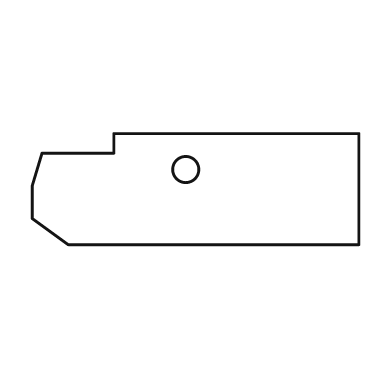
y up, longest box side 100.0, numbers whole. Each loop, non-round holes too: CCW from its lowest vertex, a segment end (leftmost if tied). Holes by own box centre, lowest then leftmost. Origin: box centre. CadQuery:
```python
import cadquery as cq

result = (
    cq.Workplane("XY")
    .moveTo(-39.0, -17.0)
    .lineTo(50.0, -17.0)
    .lineTo(50.0, 17.0)
    .lineTo(-25.0, 17.0)
    .lineTo(-25.0, 11.0)
    .lineTo(-47.0, 11.0)
    .lineTo(-50.0, 1.0)
    .lineTo(-50.0, -9.0)
    .close()
    .moveTo(-3.0, 6.0)
    .circle(4.0)
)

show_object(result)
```